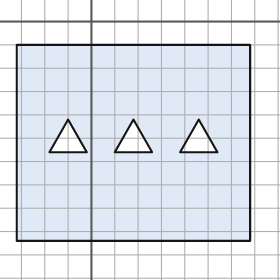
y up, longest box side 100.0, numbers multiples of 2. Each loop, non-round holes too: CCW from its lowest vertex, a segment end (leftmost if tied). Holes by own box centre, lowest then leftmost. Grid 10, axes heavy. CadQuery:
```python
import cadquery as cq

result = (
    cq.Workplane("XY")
    .moveTo(-32.0, -94.0)
    .lineTo(68.0, -94.0)
    .lineTo(68.0, -10.0)
    .lineTo(-32.0, -10.0)
    .close()
    .moveTo(-18.0, -56.0)
    .lineTo(-2.0, -56.0)
    .lineTo(-10.0, -42.0)
    .close()
    .moveTo(10.0, -56.0)
    .lineTo(26.0, -56.0)
    .lineTo(18.0, -42.0)
    .close()
    .moveTo(38.0, -56.0)
    .lineTo(54.0, -56.0)
    .lineTo(46.0, -42.0)
    .close()
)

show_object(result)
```